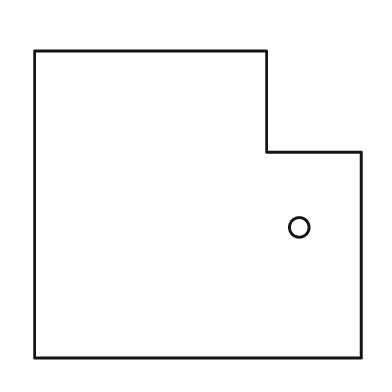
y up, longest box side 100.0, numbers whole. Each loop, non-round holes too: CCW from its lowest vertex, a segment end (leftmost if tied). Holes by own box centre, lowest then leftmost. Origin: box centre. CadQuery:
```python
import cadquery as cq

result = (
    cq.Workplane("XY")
    .moveTo(-50.0, -47.0)
    .lineTo(50.0, -47.0)
    .lineTo(50.0, 16.0)
    .lineTo(21.0, 16.0)
    .lineTo(21.0, 47.0)
    .lineTo(-50.0, 47.0)
    .close()
    .moveTo(31.0, -7.0)
    .circle(3.0)
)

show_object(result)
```